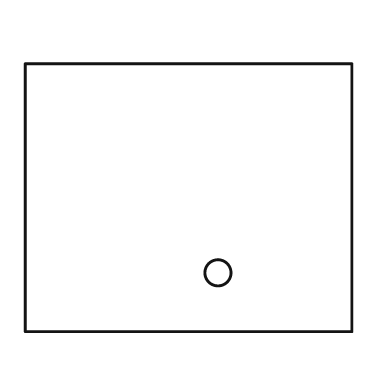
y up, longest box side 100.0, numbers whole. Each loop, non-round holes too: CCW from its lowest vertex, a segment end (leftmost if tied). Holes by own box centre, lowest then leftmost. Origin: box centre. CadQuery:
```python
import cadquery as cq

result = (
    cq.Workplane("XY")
    .moveTo(-50.0, -41.0)
    .lineTo(50.0, -41.0)
    .lineTo(50.0, 41.0)
    .lineTo(-50.0, 41.0)
    .close()
    .moveTo(9.0, -23.0)
    .circle(4.0)
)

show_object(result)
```